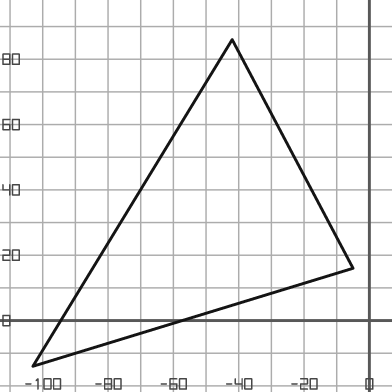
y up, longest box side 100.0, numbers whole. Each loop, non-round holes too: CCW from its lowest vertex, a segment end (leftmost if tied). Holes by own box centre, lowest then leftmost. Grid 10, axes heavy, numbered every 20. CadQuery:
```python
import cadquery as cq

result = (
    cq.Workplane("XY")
    .moveTo(-103.0, -14.0)
    .lineTo(-5.0, 16.0)
    .lineTo(-42.0, 86.0)
    .close()
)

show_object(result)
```